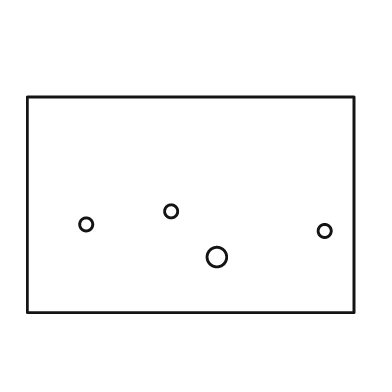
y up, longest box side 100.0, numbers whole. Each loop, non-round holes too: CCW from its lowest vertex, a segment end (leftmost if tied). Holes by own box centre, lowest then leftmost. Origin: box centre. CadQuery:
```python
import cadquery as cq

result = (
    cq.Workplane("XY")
    .moveTo(-50.0, -33.0)
    .lineTo(50.0, -33.0)
    .lineTo(50.0, 33.0)
    .lineTo(-50.0, 33.0)
    .close()
    .moveTo(8.0, -16.0)
    .circle(3.0)
    .moveTo(41.0, -8.0)
    .circle(2.0)
    .moveTo(-32.0, -6.0)
    .circle(2.0)
    .moveTo(-6.0, -2.0)
    .circle(2.0)
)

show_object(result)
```